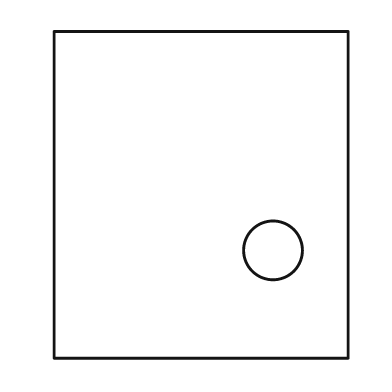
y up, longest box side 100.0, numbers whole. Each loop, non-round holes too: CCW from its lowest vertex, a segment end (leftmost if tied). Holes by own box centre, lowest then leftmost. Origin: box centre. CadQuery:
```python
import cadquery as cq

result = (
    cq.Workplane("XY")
    .moveTo(-45.0, -50.0)
    .lineTo(45.0, -50.0)
    .lineTo(45.0, 50.0)
    .lineTo(-45.0, 50.0)
    .close()
    .moveTo(22.0, -17.0)
    .circle(9.0)
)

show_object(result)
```